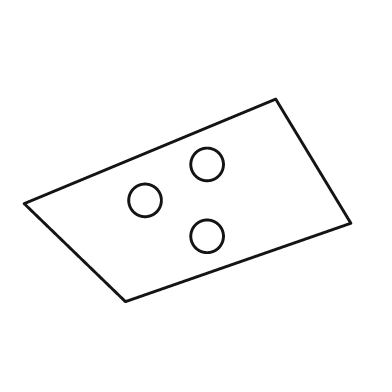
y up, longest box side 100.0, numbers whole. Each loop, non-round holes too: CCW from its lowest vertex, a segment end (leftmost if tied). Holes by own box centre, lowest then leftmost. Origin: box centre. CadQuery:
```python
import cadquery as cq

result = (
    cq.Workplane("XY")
    .moveTo(-19.0, -31.0)
    .lineTo(50.0, -7.0)
    .lineTo(27.0, 31.0)
    .lineTo(-50.0, -1.0)
    .close()
    .moveTo(6.0, -11.0)
    .circle(5.0)
    .moveTo(-13.0, 0.0)
    .circle(5.0)
    .moveTo(6.0, 11.0)
    .circle(5.0)
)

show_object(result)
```